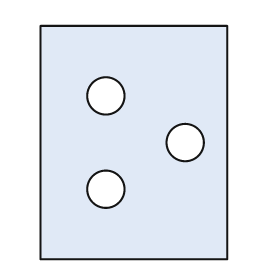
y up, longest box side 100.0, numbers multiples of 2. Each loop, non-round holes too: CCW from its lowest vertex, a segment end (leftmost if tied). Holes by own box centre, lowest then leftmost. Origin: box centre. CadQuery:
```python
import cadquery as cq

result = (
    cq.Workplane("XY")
    .moveTo(-40.0, -50.0)
    .lineTo(40.0, -50.0)
    .lineTo(40.0, 50.0)
    .lineTo(-40.0, 50.0)
    .close()
    .moveTo(-12.0, -20.0)
    .circle(8.0)
    .moveTo(22.0, 0.0)
    .circle(8.0)
    .moveTo(-12.0, 20.0)
    .circle(8.0)
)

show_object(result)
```